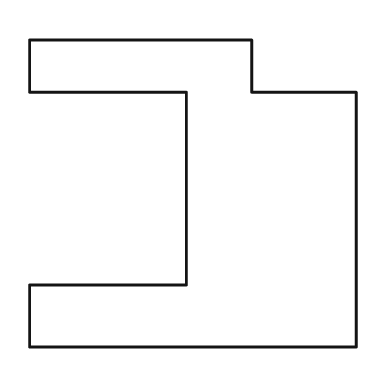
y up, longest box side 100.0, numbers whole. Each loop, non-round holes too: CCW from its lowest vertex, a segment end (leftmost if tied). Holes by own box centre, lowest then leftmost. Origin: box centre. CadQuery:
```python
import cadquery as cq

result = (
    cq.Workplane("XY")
    .moveTo(-50.0, -47.0)
    .lineTo(50.0, -47.0)
    .lineTo(50.0, 31.0)
    .lineTo(18.0, 31.0)
    .lineTo(18.0, 47.0)
    .lineTo(-50.0, 47.0)
    .lineTo(-50.0, 31.0)
    .lineTo(-2.0, 31.0)
    .lineTo(-2.0, -28.0)
    .lineTo(-50.0, -28.0)
    .close()
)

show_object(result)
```